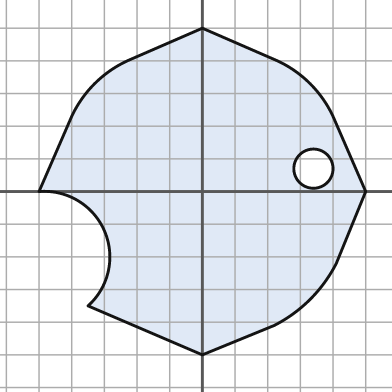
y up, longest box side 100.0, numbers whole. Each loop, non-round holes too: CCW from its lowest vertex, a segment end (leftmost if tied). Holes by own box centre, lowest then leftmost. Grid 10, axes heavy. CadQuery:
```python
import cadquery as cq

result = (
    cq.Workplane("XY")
    .moveTo(0.0, -50.0)
    .lineTo(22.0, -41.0)
    .threePointArc((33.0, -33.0), (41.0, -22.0))
    .lineTo(50.0, 0.0)
    .lineTo(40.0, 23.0)
    .threePointArc((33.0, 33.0), (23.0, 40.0))
    .lineTo(0.0, 50.0)
    .lineTo(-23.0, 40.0)
    .threePointArc((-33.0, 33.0), (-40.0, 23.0))
    .lineTo(-50.0, 0.0)
    .threePointArc((-30.0, -12.0), (-35.0, -35.0))
    .close()
    .moveTo(34.0, 7.0)
    .circle(6.0)
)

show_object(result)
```